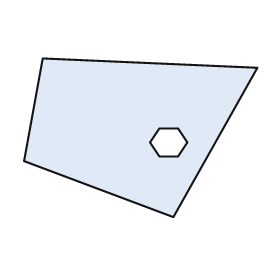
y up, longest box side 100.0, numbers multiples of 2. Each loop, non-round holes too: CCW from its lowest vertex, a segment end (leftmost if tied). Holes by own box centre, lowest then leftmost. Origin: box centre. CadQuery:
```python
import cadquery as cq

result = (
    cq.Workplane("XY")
    .moveTo(14.0, -34.0)
    .lineTo(50.0, 30.0)
    .lineTo(-42.0, 34.0)
    .lineTo(-50.0, -10.0)
    .close()
    .moveTo(8.0, -8.0)
    .lineTo(16.0, -8.0)
    .lineTo(20.0, -2.0)
    .lineTo(16.0, 4.0)
    .lineTo(8.0, 4.0)
    .lineTo(4.0, -2.0)
    .close()
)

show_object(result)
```